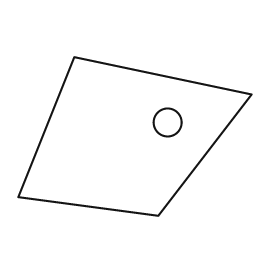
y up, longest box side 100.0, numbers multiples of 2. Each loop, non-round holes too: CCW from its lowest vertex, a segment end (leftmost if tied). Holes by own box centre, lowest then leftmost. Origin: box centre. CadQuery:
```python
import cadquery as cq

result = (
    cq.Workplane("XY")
    .moveTo(10.0, -34.0)
    .lineTo(50.0, 18.0)
    .lineTo(-26.0, 34.0)
    .lineTo(-50.0, -26.0)
    .close()
    .moveTo(14.0, 6.0)
    .circle(6.0)
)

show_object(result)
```